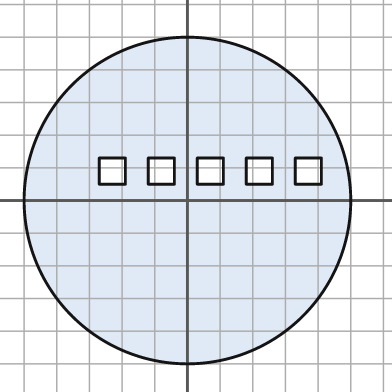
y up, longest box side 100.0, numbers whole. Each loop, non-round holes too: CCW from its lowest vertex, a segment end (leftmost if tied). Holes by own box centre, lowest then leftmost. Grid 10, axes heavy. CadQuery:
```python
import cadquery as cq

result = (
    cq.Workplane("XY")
    .moveTo(0.0, 0.0)
    .circle(50.0)
    .moveTo(-27.0, 5.0)
    .lineTo(-19.0, 5.0)
    .lineTo(-19.0, 13.0)
    .lineTo(-27.0, 13.0)
    .close()
    .moveTo(-12.0, 5.0)
    .lineTo(-4.0, 5.0)
    .lineTo(-4.0, 13.0)
    .lineTo(-12.0, 13.0)
    .close()
    .moveTo(3.0, 5.0)
    .lineTo(11.0, 5.0)
    .lineTo(11.0, 13.0)
    .lineTo(3.0, 13.0)
    .close()
    .moveTo(18.0, 5.0)
    .lineTo(26.0, 5.0)
    .lineTo(26.0, 13.0)
    .lineTo(18.0, 13.0)
    .close()
    .moveTo(33.0, 5.0)
    .lineTo(41.0, 5.0)
    .lineTo(41.0, 13.0)
    .lineTo(33.0, 13.0)
    .close()
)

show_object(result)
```